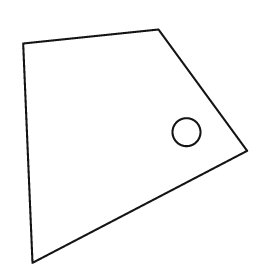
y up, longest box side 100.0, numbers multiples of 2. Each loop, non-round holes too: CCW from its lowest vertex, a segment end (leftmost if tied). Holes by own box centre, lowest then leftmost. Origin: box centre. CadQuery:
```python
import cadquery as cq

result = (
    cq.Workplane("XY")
    .moveTo(-44.0, -50.0)
    .lineTo(48.0, -2.0)
    .lineTo(10.0, 50.0)
    .lineTo(-48.0, 44.0)
    .close()
    .moveTo(22.0, 6.0)
    .circle(6.0)
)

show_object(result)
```